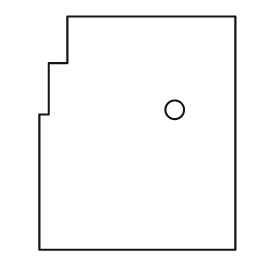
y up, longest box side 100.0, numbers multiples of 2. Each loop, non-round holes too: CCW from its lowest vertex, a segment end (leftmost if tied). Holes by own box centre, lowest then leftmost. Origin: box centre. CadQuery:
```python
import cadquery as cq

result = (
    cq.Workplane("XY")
    .moveTo(-42.0, -50.0)
    .lineTo(42.0, -50.0)
    .lineTo(42.0, 50.0)
    .lineTo(-30.0, 50.0)
    .lineTo(-30.0, 30.0)
    .lineTo(-38.0, 30.0)
    .lineTo(-38.0, 8.0)
    .lineTo(-42.0, 8.0)
    .close()
    .moveTo(16.0, 10.0)
    .circle(4.0)
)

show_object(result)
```